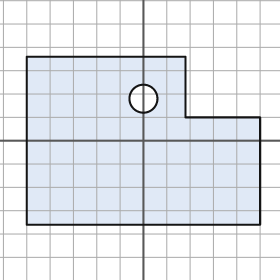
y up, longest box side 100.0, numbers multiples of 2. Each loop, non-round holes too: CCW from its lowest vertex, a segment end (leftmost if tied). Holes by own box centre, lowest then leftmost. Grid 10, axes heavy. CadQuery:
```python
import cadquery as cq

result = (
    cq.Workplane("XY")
    .moveTo(-50.0, -36.0)
    .lineTo(50.0, -36.0)
    .lineTo(50.0, 10.0)
    .lineTo(18.0, 10.0)
    .lineTo(18.0, 36.0)
    .lineTo(-50.0, 36.0)
    .close()
    .moveTo(0.0, 18.0)
    .circle(6.0)
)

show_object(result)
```